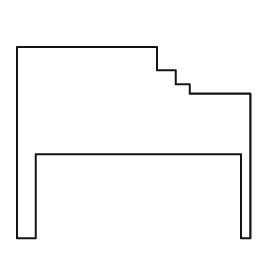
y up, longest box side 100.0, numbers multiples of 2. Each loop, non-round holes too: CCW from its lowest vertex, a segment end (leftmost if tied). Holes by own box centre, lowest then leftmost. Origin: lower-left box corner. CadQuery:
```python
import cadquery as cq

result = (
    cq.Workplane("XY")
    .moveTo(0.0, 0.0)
    .lineTo(8.0, 0.0)
    .lineTo(8.0, 36.0)
    .lineTo(96.0, 36.0)
    .lineTo(96.0, 0.0)
    .lineTo(100.0, 0.0)
    .lineTo(100.0, 62.0)
    .lineTo(74.0, 62.0)
    .lineTo(74.0, 66.0)
    .lineTo(68.0, 66.0)
    .lineTo(68.0, 72.0)
    .lineTo(60.0, 72.0)
    .lineTo(60.0, 82.0)
    .lineTo(0.0, 82.0)
    .close()
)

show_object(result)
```